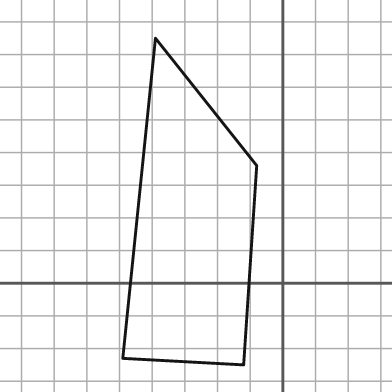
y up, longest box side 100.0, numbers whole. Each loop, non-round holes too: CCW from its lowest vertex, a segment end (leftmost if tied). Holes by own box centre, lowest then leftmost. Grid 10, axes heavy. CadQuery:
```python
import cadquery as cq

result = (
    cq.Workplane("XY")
    .moveTo(-12.0, -25.0)
    .lineTo(-8.0, 36.0)
    .lineTo(-39.0, 75.0)
    .lineTo(-49.0, -23.0)
    .close()
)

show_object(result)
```